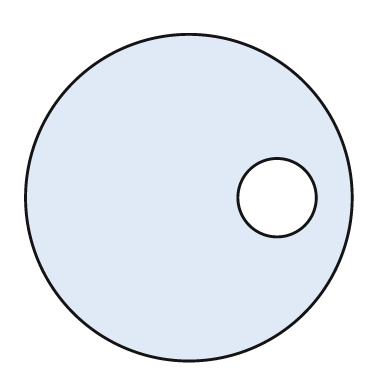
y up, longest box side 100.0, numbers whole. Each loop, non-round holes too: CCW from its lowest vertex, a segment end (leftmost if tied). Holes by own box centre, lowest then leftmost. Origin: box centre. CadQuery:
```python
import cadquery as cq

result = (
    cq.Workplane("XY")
    .moveTo(0.0, 0.0)
    .circle(50.0)
    .moveTo(27.0, 0.0)
    .circle(12.0)
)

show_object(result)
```